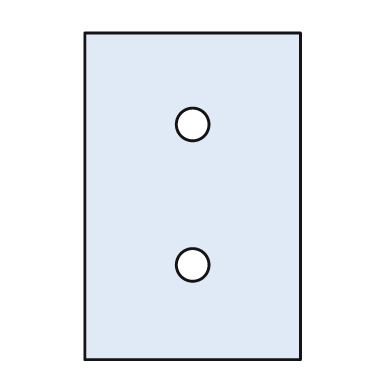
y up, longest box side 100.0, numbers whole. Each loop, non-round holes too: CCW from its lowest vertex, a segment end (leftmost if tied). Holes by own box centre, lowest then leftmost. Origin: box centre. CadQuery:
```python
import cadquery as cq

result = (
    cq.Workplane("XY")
    .moveTo(-33.0, -50.0)
    .lineTo(33.0, -50.0)
    .lineTo(33.0, 50.0)
    .lineTo(-33.0, 50.0)
    .close()
    .moveTo(0.0, -21.0)
    .circle(5.0)
    .moveTo(0.0, 22.0)
    .circle(5.0)
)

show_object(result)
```